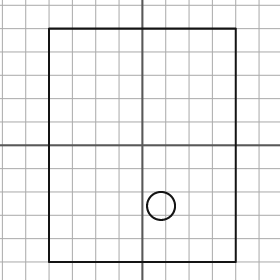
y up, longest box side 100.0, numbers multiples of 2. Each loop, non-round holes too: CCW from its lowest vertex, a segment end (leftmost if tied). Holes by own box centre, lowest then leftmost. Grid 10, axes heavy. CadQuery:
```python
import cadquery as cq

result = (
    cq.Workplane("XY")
    .moveTo(-40.0, -50.0)
    .lineTo(40.0, -50.0)
    .lineTo(40.0, 50.0)
    .lineTo(-40.0, 50.0)
    .close()
    .moveTo(8.0, -26.0)
    .circle(6.0)
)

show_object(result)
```